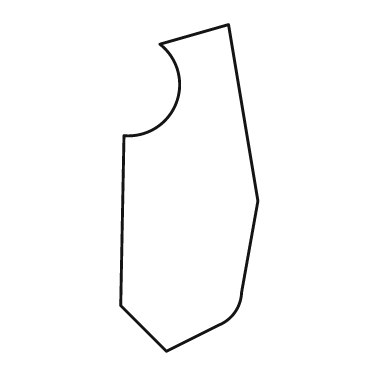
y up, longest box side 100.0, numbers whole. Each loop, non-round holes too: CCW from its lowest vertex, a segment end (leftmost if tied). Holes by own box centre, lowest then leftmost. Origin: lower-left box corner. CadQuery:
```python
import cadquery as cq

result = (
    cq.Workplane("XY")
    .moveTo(14.0, 0.0)
    .lineTo(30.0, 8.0)
    .threePointArc((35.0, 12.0), (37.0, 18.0))
    .lineTo(42.0, 46.0)
    .lineTo(33.0, 100.0)
    .lineTo(12.0, 94.0)
    .threePointArc((17.0, 76.0), (1.0, 66.0))
    .lineTo(0.0, 14.0)
    .close()
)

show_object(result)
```